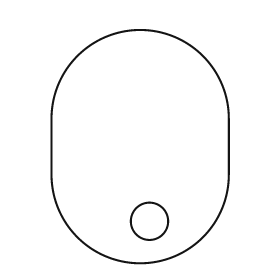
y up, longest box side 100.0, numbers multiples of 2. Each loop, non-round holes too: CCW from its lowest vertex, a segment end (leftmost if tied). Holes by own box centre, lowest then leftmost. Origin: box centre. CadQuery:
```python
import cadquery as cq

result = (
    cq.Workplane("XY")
    .moveTo(-38.0, -12.0)
    .threePointArc((0.0, -50.0), (38.0, -12.0))
    .lineTo(38.0, 12.0)
    .threePointArc((0.0, 50.0), (-38.0, 12.0))
    .close()
    .moveTo(4.0, -32.0)
    .circle(8.0)
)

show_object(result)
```